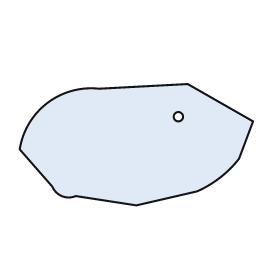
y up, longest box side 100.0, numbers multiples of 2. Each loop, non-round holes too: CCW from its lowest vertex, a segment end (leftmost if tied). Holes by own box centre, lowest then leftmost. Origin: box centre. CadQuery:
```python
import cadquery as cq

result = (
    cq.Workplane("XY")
    .moveTo(0.0, -26.0)
    .lineTo(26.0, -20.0)
    .threePointArc((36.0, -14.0), (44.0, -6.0))
    .lineTo(50.0, 10.0)
    .lineTo(22.0, 26.0)
    .lineTo(-16.0, 24.0)
    .threePointArc((-38.0, 18.0), (-50.0, -2.0))
    .lineTo(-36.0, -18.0)
    .threePointArc((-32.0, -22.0), (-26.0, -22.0))
    .close()
    .moveTo(18.0, 12.0)
    .circle(2.0)
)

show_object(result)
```